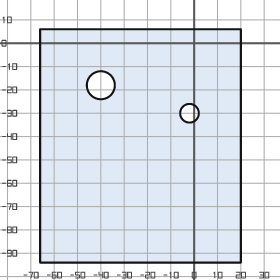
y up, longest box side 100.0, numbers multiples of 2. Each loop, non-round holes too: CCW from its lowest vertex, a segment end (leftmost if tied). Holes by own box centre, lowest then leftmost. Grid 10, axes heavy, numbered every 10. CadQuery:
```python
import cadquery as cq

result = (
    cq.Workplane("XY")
    .moveTo(-66.0, -94.0)
    .lineTo(20.0, -94.0)
    .lineTo(20.0, 6.0)
    .lineTo(-66.0, 6.0)
    .close()
    .moveTo(-2.0, -30.0)
    .circle(4.0)
    .moveTo(-40.0, -18.0)
    .circle(6.0)
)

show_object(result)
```